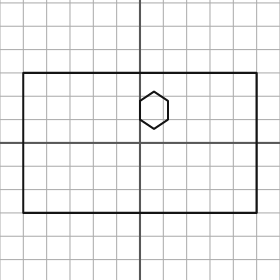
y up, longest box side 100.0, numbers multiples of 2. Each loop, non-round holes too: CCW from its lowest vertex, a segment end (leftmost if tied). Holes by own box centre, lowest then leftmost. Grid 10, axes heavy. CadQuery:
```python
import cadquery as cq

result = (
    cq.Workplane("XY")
    .moveTo(-50.0, -30.0)
    .lineTo(50.0, -30.0)
    .lineTo(50.0, 30.0)
    .lineTo(-50.0, 30.0)
    .close()
    .moveTo(6.0, 6.0)
    .lineTo(12.0, 10.0)
    .lineTo(12.0, 18.0)
    .lineTo(6.0, 22.0)
    .lineTo(0.0, 18.0)
    .lineTo(0.0, 10.0)
    .close()
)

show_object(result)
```